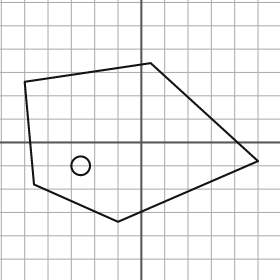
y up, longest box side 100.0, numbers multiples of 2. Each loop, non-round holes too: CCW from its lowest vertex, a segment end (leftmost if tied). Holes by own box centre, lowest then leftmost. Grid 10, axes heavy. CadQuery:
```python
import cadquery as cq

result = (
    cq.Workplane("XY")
    .moveTo(-10.0, -34.0)
    .lineTo(50.0, -8.0)
    .lineTo(4.0, 34.0)
    .lineTo(-50.0, 26.0)
    .lineTo(-46.0, -18.0)
    .close()
    .moveTo(-26.0, -10.0)
    .circle(4.0)
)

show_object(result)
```